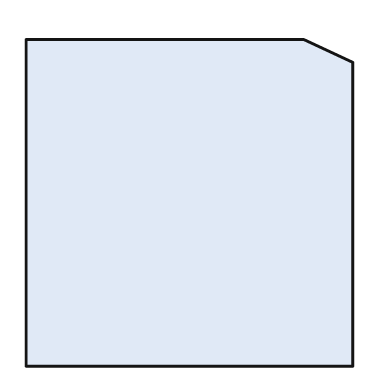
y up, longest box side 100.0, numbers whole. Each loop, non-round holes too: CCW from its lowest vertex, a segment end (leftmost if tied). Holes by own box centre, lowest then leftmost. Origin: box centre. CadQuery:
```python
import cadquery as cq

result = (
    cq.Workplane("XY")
    .moveTo(-50.0, -50.0)
    .lineTo(50.0, -50.0)
    .lineTo(50.0, 43.0)
    .lineTo(35.0, 50.0)
    .lineTo(-50.0, 50.0)
    .close()
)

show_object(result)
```